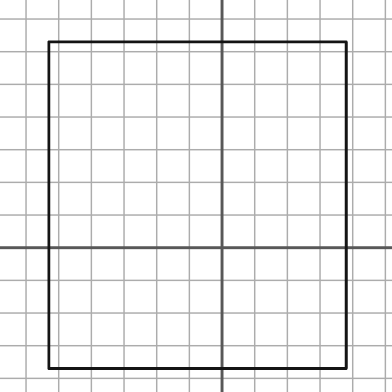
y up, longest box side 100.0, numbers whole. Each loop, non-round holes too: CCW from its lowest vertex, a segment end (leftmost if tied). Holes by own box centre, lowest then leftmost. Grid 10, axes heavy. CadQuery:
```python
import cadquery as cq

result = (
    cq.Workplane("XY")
    .moveTo(-53.0, -37.0)
    .lineTo(38.0, -37.0)
    .lineTo(38.0, 63.0)
    .lineTo(-53.0, 63.0)
    .close()
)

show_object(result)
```